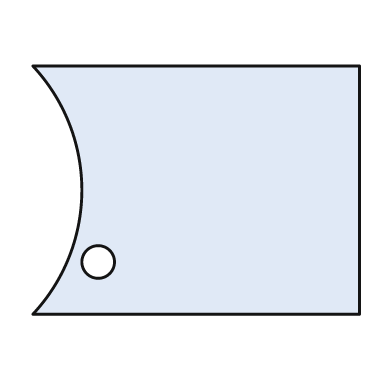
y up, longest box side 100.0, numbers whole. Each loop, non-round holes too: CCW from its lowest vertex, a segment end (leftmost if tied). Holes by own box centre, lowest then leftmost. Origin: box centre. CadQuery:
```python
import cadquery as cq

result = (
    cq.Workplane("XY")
    .moveTo(-50.0, -38.0)
    .lineTo(50.0, -38.0)
    .lineTo(50.0, 38.0)
    .lineTo(-50.0, 38.0)
    .threePointArc((-35.0, 0.0), (-50.0, -38.0))
    .close()
    .moveTo(-30.0, -22.0)
    .circle(5.0)
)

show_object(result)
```